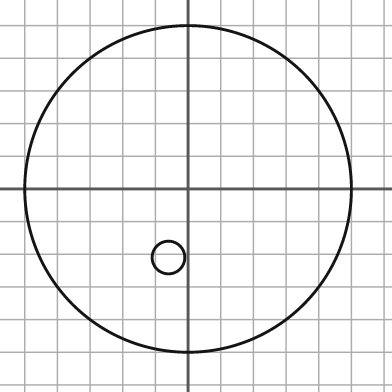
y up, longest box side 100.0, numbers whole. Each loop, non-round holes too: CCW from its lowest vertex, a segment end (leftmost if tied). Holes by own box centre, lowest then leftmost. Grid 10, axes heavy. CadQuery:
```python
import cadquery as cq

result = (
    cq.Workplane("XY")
    .moveTo(0.0, 0.0)
    .circle(50.0)
    .moveTo(-6.0, -21.0)
    .circle(5.0)
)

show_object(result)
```